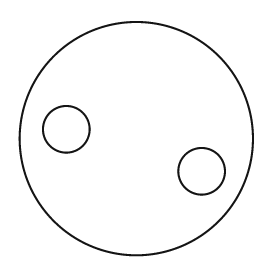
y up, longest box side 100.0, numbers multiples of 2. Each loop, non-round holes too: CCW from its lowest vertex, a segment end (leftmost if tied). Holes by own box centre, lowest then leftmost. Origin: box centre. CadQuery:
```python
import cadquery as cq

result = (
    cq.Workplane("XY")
    .moveTo(0.0, 0.0)
    .circle(50.0)
    .moveTo(28.0, -14.0)
    .circle(10.0)
    .moveTo(-30.0, 4.0)
    .circle(10.0)
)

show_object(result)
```